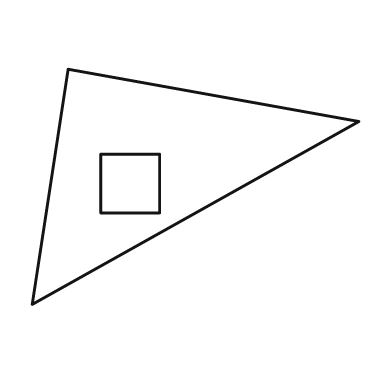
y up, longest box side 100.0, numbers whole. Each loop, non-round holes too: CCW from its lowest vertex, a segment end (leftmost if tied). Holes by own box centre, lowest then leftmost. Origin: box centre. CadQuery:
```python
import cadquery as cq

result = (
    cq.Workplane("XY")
    .moveTo(-50.0, -36.0)
    .lineTo(50.0, 20.0)
    .lineTo(-39.0, 36.0)
    .close()
    .moveTo(-29.0, -8.0)
    .lineTo(-11.0, -8.0)
    .lineTo(-11.0, 10.0)
    .lineTo(-29.0, 10.0)
    .close()
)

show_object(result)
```